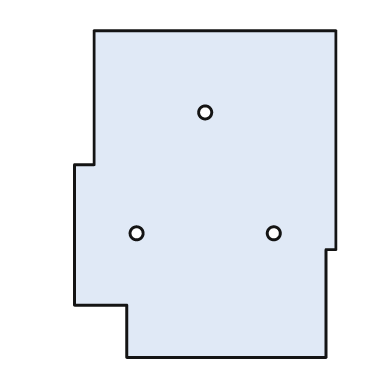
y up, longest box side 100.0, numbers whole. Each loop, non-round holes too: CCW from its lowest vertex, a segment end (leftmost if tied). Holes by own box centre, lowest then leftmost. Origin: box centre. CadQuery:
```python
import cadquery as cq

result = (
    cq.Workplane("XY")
    .moveTo(-24.0, -50.0)
    .lineTo(37.0, -50.0)
    .lineTo(37.0, -17.0)
    .lineTo(40.0, -17.0)
    .lineTo(40.0, 50.0)
    .lineTo(-34.0, 50.0)
    .lineTo(-34.0, 9.0)
    .lineTo(-40.0, 9.0)
    .lineTo(-40.0, -34.0)
    .lineTo(-24.0, -34.0)
    .close()
    .moveTo(-21.0, -12.0)
    .circle(2.0)
    .moveTo(21.0, -12.0)
    .circle(2.0)
    .moveTo(0.0, 25.0)
    .circle(2.0)
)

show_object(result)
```